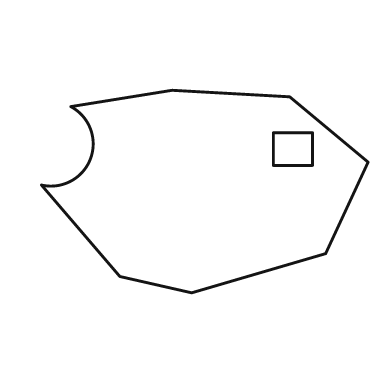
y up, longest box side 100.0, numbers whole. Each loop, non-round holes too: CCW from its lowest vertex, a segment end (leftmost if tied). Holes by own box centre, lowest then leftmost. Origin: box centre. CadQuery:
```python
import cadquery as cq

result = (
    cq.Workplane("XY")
    .moveTo(-4.0, -31.0)
    .lineTo(37.0, -19.0)
    .lineTo(50.0, 9.0)
    .lineTo(26.0, 29.0)
    .lineTo(-10.0, 31.0)
    .lineTo(-41.0, 26.0)
    .threePointArc((-35.0, 10.0), (-50.0, 2.0))
    .lineTo(-26.0, -26.0)
    .close()
    .moveTo(21.0, 8.0)
    .lineTo(33.0, 8.0)
    .lineTo(33.0, 18.0)
    .lineTo(21.0, 18.0)
    .close()
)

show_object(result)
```